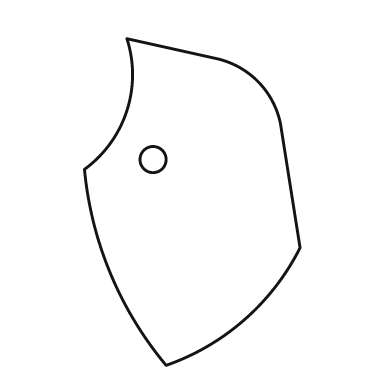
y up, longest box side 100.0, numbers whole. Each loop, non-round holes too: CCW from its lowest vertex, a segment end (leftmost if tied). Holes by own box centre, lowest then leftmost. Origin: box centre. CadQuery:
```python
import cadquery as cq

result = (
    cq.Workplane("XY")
    .moveTo(-8.0, -50.0)
    .threePointArc((16.0, -36.0), (33.0, -14.0))
    .lineTo(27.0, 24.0)
    .threePointArc((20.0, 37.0), (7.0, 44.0))
    .lineTo(-20.0, 50.0)
    .threePointArc((-20.0, 28.0), (-33.0, 10.0))
    .threePointArc((-25.0, -22.0), (-8.0, -50.0))
    .close()
    .moveTo(-12.0, 13.0)
    .circle(4.0)
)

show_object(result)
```